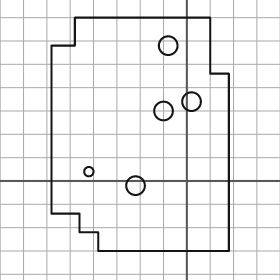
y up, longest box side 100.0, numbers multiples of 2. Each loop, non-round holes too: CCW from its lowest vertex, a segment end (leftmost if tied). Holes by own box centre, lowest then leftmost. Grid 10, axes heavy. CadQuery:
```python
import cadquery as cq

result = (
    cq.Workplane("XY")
    .moveTo(-38.0, -30.0)
    .lineTo(18.0, -30.0)
    .lineTo(18.0, 46.0)
    .lineTo(10.0, 46.0)
    .lineTo(10.0, 70.0)
    .lineTo(-48.0, 70.0)
    .lineTo(-48.0, 58.0)
    .lineTo(-58.0, 58.0)
    .lineTo(-58.0, -14.0)
    .lineTo(-46.0, -14.0)
    .lineTo(-46.0, -22.0)
    .lineTo(-38.0, -22.0)
    .close()
    .moveTo(-22.0, -2.0)
    .circle(4.0)
    .moveTo(-42.0, 4.0)
    .circle(2.0)
    .moveTo(-10.0, 30.0)
    .circle(4.0)
    .moveTo(2.0, 34.0)
    .circle(4.0)
    .moveTo(-8.0, 58.0)
    .circle(4.0)
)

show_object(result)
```